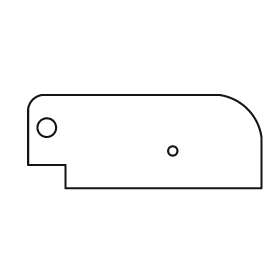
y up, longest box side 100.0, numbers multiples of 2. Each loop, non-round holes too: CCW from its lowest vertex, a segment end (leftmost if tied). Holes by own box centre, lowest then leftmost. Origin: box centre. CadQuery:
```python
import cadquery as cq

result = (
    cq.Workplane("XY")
    .moveTo(-34.0, -20.0)
    .lineTo(50.0, -20.0)
    .lineTo(50.0, 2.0)
    .threePointArc((44.0, 14.0), (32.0, 20.0))
    .lineTo(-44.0, 20.0)
    .threePointArc((-48.0, 18.0), (-50.0, 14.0))
    .lineTo(-50.0, -10.0)
    .lineTo(-34.0, -10.0)
    .close()
    .moveTo(12.0, -4.0)
    .circle(2.0)
    .moveTo(-42.0, 6.0)
    .circle(4.0)
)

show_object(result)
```